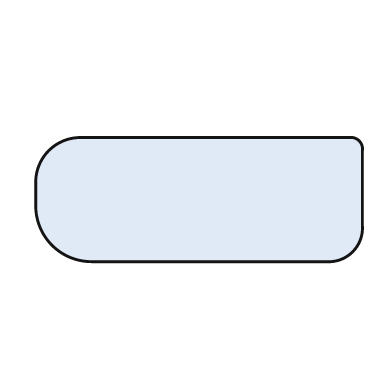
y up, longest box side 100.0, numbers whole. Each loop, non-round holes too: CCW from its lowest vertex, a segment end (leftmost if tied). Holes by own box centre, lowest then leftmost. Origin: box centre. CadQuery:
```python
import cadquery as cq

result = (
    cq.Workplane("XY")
    .moveTo(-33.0, -19.0)
    .lineTo(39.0, -19.0)
    .threePointArc((47.0, -16.0), (50.0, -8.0))
    .lineTo(50.0, 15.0)
    .threePointArc((49.0, 18.0), (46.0, 19.0))
    .lineTo(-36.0, 19.0)
    .threePointArc((-46.0, 15.0), (-50.0, 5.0))
    .lineTo(-50.0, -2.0)
    .threePointArc((-45.0, -14.0), (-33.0, -19.0))
    .close()
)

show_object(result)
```